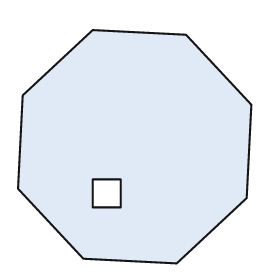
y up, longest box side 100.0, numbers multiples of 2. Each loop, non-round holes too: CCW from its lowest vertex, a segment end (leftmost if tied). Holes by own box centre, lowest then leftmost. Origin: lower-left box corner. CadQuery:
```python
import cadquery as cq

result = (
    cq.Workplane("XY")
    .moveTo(68.0, 0.0)
    .lineTo(98.0, 28.0)
    .lineTo(100.0, 68.0)
    .lineTo(72.0, 98.0)
    .lineTo(32.0, 100.0)
    .lineTo(2.0, 72.0)
    .lineTo(0.0, 32.0)
    .lineTo(28.0, 2.0)
    .close()
    .moveTo(32.0, 24.0)
    .lineTo(44.0, 24.0)
    .lineTo(44.0, 36.0)
    .lineTo(32.0, 36.0)
    .close()
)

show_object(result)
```